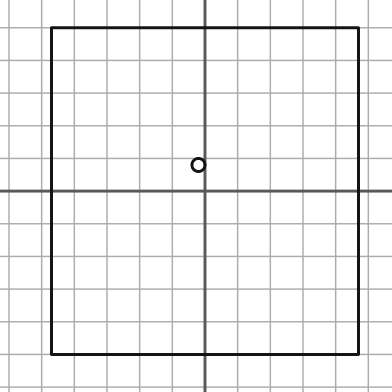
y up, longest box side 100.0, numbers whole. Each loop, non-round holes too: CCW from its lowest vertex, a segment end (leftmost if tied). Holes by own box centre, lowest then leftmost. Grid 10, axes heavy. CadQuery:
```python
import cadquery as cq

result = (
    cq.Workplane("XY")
    .moveTo(-47.0, -50.0)
    .lineTo(47.0, -50.0)
    .lineTo(47.0, 50.0)
    .lineTo(-47.0, 50.0)
    .close()
    .moveTo(-2.0, 8.0)
    .circle(2.0)
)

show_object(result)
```